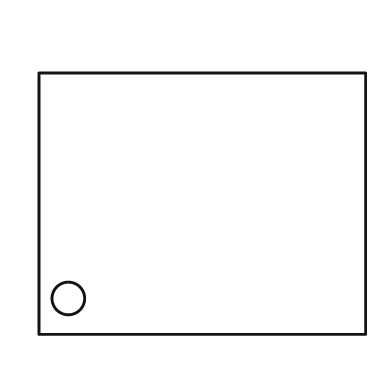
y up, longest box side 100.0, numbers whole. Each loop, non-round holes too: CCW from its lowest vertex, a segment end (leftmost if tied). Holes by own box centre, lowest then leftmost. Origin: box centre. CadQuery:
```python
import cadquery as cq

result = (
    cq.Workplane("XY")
    .moveTo(-50.0, -40.0)
    .lineTo(50.0, -40.0)
    .lineTo(50.0, 40.0)
    .lineTo(-50.0, 40.0)
    .close()
    .moveTo(-41.0, -29.0)
    .circle(5.0)
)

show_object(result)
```